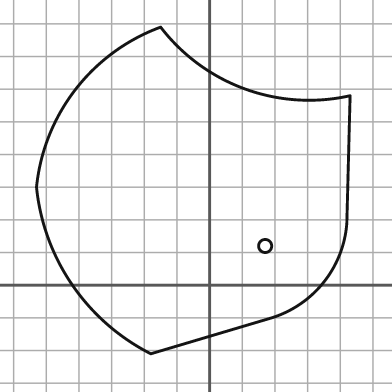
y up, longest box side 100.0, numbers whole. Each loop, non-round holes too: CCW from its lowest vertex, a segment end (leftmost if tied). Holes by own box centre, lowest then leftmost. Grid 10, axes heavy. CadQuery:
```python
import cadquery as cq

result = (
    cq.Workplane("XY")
    .moveTo(-18.0, -21.0)
    .lineTo(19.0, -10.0)
    .threePointArc((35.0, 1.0), (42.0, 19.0))
    .lineTo(43.0, 58.0)
    .threePointArc((11.0, 60.0), (-15.0, 79.0))
    .threePointArc((-41.0, 60.0), (-53.0, 30.0))
    .threePointArc((-42.0, 0.0), (-18.0, -21.0))
    .close()
    .moveTo(17.0, 12.0)
    .circle(2.0)
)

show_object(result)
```